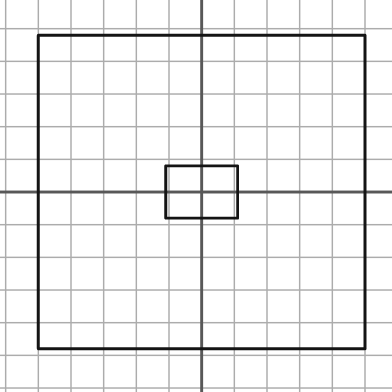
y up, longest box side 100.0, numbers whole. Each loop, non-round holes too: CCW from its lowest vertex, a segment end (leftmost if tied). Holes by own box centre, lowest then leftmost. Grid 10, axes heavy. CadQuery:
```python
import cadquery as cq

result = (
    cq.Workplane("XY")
    .moveTo(-50.0, -48.0)
    .lineTo(50.0, -48.0)
    .lineTo(50.0, 48.0)
    .lineTo(-50.0, 48.0)
    .close()
    .moveTo(-11.0, -8.0)
    .lineTo(11.0, -8.0)
    .lineTo(11.0, 8.0)
    .lineTo(-11.0, 8.0)
    .close()
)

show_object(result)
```